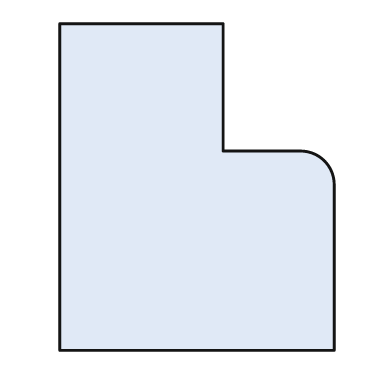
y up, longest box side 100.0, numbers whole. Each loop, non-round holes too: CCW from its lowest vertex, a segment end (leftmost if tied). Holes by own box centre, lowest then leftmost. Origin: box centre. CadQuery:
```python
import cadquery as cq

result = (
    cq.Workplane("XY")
    .moveTo(-42.0, -50.0)
    .lineTo(42.0, -50.0)
    .lineTo(42.0, 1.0)
    .threePointArc((39.0, 8.0), (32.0, 11.0))
    .lineTo(8.0, 11.0)
    .lineTo(8.0, 50.0)
    .lineTo(-42.0, 50.0)
    .close()
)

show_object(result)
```